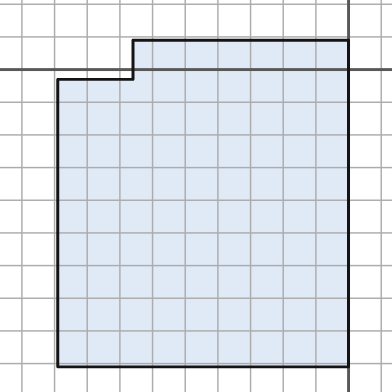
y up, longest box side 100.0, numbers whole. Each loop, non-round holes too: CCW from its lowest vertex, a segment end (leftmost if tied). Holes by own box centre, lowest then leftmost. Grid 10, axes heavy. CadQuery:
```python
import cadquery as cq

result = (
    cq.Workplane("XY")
    .moveTo(-89.0, -91.0)
    .lineTo(0.0, -91.0)
    .lineTo(0.0, 9.0)
    .lineTo(-66.0, 9.0)
    .lineTo(-66.0, -3.0)
    .lineTo(-89.0, -3.0)
    .close()
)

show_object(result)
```